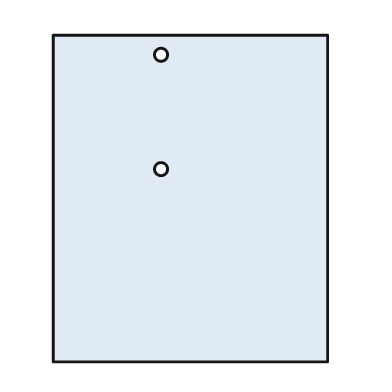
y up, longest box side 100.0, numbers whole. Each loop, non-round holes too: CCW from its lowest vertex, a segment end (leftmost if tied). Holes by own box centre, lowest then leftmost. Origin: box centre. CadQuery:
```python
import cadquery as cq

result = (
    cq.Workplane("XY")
    .moveTo(-42.0, -50.0)
    .lineTo(42.0, -50.0)
    .lineTo(42.0, 50.0)
    .lineTo(-42.0, 50.0)
    .close()
    .moveTo(-9.0, 9.0)
    .circle(2.0)
    .moveTo(-9.0, 44.0)
    .circle(2.0)
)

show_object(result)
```